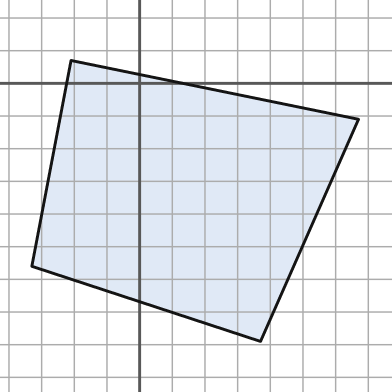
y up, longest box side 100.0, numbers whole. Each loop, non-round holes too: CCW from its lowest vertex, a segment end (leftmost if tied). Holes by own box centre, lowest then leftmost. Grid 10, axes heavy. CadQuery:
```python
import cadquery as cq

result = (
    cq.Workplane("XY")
    .moveTo(37.0, -79.0)
    .lineTo(67.0, -11.0)
    .lineTo(-21.0, 7.0)
    .lineTo(-33.0, -56.0)
    .close()
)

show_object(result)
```